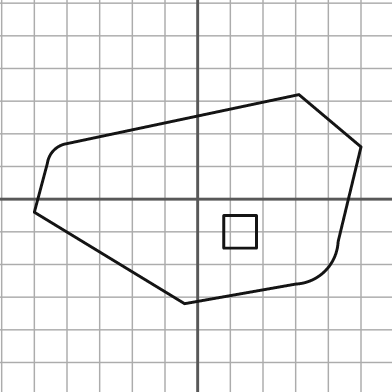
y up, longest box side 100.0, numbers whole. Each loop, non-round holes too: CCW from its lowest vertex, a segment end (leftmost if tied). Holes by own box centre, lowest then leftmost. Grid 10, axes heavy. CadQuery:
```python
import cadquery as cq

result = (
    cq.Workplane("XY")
    .moveTo(-4.0, -32.0)
    .lineTo(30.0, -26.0)
    .threePointArc((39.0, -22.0), (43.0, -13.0))
    .lineTo(50.0, 16.0)
    .lineTo(31.0, 32.0)
    .lineTo(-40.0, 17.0)
    .threePointArc((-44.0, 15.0), (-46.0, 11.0))
    .lineTo(-50.0, -4.0)
    .close()
    .moveTo(8.0, -15.0)
    .lineTo(18.0, -15.0)
    .lineTo(18.0, -5.0)
    .lineTo(8.0, -5.0)
    .close()
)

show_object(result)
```